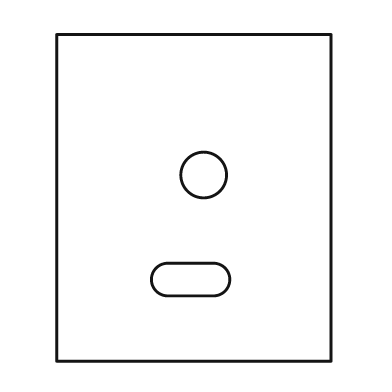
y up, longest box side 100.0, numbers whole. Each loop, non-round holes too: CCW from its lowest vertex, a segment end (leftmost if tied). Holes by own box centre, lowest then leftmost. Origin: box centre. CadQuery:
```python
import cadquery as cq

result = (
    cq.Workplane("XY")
    .moveTo(-42.0, -50.0)
    .lineTo(42.0, -50.0)
    .lineTo(42.0, 50.0)
    .lineTo(-42.0, 50.0)
    .close()
    .moveTo(-8.0, -30.0)
    .lineTo(6.0, -30.0)
    .threePointArc((11.0, -25.0), (6.0, -20.0))
    .lineTo(-8.0, -20.0)
    .threePointArc((-13.0, -25.0), (-8.0, -30.0))
    .close()
    .moveTo(3.0, 7.0)
    .circle(7.0)
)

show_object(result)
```